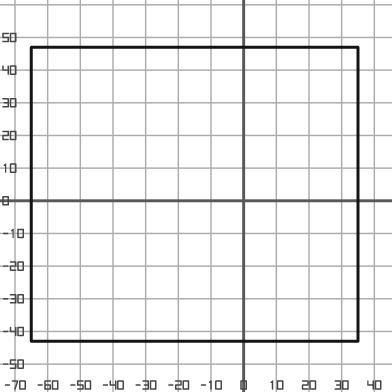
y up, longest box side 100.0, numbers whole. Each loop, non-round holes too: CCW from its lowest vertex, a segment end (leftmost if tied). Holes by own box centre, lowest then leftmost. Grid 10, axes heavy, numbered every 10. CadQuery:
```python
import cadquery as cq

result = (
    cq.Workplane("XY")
    .moveTo(-65.0, -43.0)
    .lineTo(35.0, -43.0)
    .lineTo(35.0, 47.0)
    .lineTo(-65.0, 47.0)
    .close()
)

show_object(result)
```